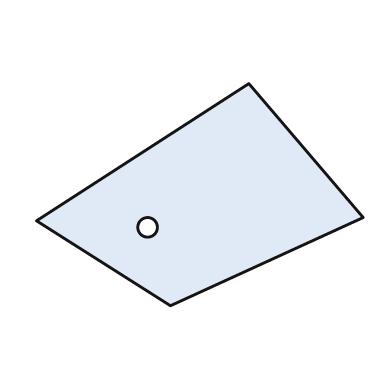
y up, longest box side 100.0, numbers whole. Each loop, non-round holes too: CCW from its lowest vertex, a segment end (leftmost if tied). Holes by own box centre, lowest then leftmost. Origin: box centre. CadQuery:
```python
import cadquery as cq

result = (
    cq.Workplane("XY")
    .moveTo(-9.0, -34.0)
    .lineTo(50.0, -7.0)
    .lineTo(15.0, 34.0)
    .lineTo(-50.0, -8.0)
    .close()
    .moveTo(-16.0, -10.0)
    .circle(3.0)
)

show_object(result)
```